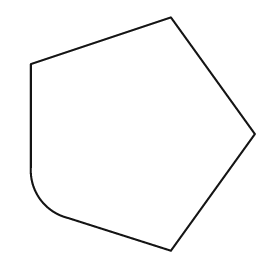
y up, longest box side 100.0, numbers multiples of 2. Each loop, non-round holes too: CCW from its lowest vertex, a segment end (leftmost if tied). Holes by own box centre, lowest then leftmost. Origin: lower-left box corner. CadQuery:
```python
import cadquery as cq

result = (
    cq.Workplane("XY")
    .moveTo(60.0, 0.0)
    .lineTo(96.0, 50.0)
    .lineTo(60.0, 100.0)
    .lineTo(0.0, 80.0)
    .lineTo(0.0, 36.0)
    .threePointArc((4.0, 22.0), (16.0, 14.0))
    .close()
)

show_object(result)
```